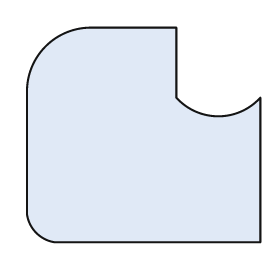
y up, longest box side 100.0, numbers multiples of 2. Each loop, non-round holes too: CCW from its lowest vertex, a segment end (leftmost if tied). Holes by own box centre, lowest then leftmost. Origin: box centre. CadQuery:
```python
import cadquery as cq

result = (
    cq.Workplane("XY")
    .moveTo(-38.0, -46.0)
    .lineTo(50.0, -46.0)
    .lineTo(50.0, 16.0)
    .threePointArc((32.0, 8.0), (14.0, 16.0))
    .lineTo(14.0, 46.0)
    .lineTo(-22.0, 46.0)
    .threePointArc((-42.0, 38.0), (-50.0, 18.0))
    .lineTo(-50.0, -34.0)
    .threePointArc((-46.0, -42.0), (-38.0, -46.0))
    .close()
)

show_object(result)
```